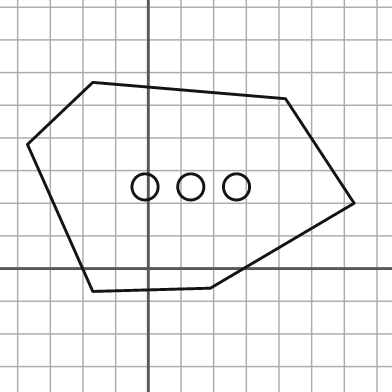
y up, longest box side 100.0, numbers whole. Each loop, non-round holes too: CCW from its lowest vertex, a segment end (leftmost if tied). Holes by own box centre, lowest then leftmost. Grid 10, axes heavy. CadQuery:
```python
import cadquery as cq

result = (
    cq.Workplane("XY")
    .moveTo(-17.0, -7.0)
    .lineTo(19.0, -6.0)
    .lineTo(63.0, 20.0)
    .lineTo(42.0, 52.0)
    .lineTo(-17.0, 57.0)
    .lineTo(-37.0, 38.0)
    .close()
    .moveTo(-1.0, 25.0)
    .circle(4.0)
    .moveTo(13.0, 25.0)
    .circle(4.0)
    .moveTo(27.0, 25.0)
    .circle(4.0)
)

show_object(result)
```